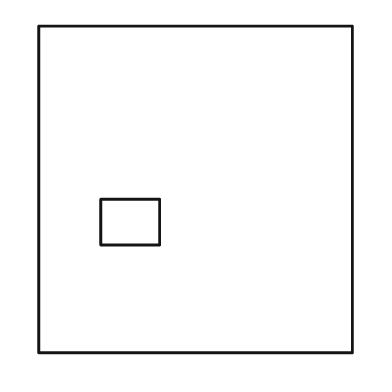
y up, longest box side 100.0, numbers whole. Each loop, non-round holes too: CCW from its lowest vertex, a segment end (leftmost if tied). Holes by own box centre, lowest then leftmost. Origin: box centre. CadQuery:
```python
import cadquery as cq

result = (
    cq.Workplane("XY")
    .moveTo(-48.0, -50.0)
    .lineTo(48.0, -50.0)
    .lineTo(48.0, 50.0)
    .lineTo(-48.0, 50.0)
    .close()
    .moveTo(-29.0, -17.0)
    .lineTo(-11.0, -17.0)
    .lineTo(-11.0, -3.0)
    .lineTo(-29.0, -3.0)
    .close()
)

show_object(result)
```